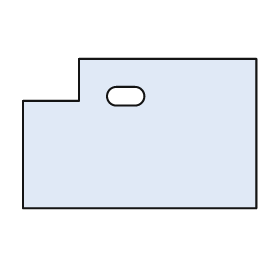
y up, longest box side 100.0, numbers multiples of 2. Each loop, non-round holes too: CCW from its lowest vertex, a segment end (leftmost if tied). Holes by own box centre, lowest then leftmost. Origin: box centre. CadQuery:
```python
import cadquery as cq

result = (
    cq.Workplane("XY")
    .moveTo(-50.0, -32.0)
    .lineTo(50.0, -32.0)
    .lineTo(50.0, 32.0)
    .lineTo(-26.0, 32.0)
    .lineTo(-26.0, 14.0)
    .lineTo(-50.0, 14.0)
    .close()
    .moveTo(-10.0, 12.0)
    .lineTo(-2.0, 12.0)
    .threePointArc((2.0, 16.0), (-2.0, 20.0))
    .lineTo(-10.0, 20.0)
    .threePointArc((-14.0, 16.0), (-10.0, 12.0))
    .close()
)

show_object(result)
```